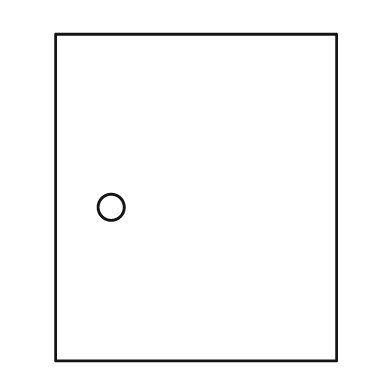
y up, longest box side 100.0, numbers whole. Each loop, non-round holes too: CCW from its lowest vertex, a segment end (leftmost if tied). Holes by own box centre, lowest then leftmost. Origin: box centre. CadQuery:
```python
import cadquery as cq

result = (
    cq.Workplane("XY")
    .moveTo(-43.0, -50.0)
    .lineTo(43.0, -50.0)
    .lineTo(43.0, 50.0)
    .lineTo(-43.0, 50.0)
    .close()
    .moveTo(-26.0, -3.0)
    .circle(4.0)
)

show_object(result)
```